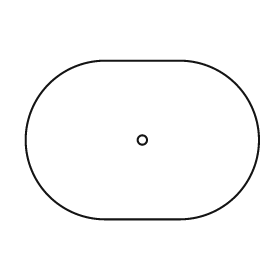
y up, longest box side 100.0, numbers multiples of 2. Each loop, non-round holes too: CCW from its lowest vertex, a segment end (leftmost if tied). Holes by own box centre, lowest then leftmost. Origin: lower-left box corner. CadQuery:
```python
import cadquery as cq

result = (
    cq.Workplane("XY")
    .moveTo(34.0, 0.0)
    .lineTo(66.0, 0.0)
    .threePointArc((100.0, 34.0), (66.0, 68.0))
    .lineTo(34.0, 68.0)
    .threePointArc((0.0, 34.0), (34.0, 0.0))
    .close()
    .moveTo(50.0, 34.0)
    .circle(2.0)
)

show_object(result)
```